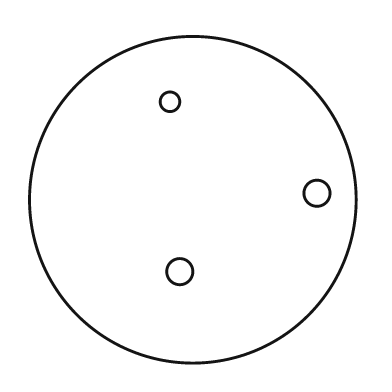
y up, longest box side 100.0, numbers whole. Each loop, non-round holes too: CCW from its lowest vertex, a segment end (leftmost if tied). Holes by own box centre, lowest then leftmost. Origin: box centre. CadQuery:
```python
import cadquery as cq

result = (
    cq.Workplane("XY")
    .moveTo(0.0, 0.0)
    .circle(50.0)
    .moveTo(-4.0, -22.0)
    .circle(4.0)
    .moveTo(38.0, 2.0)
    .circle(4.0)
    .moveTo(-7.0, 30.0)
    .circle(3.0)
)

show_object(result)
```